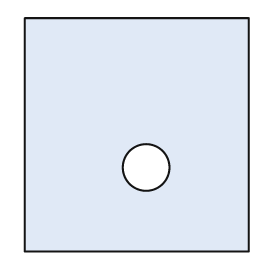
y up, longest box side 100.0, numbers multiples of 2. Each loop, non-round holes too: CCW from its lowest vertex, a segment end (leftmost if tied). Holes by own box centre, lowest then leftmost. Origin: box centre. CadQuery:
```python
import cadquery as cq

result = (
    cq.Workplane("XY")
    .moveTo(-48.0, -50.0)
    .lineTo(48.0, -50.0)
    .lineTo(48.0, 50.0)
    .lineTo(-48.0, 50.0)
    .close()
    .moveTo(4.0, -14.0)
    .circle(10.0)
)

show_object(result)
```